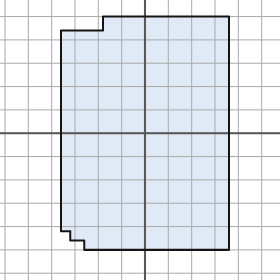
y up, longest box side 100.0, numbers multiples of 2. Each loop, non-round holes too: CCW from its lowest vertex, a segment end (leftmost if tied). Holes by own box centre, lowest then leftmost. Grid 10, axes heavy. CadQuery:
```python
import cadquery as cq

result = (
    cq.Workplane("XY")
    .moveTo(-26.0, -50.0)
    .lineTo(36.0, -50.0)
    .lineTo(36.0, 50.0)
    .lineTo(-18.0, 50.0)
    .lineTo(-18.0, 44.0)
    .lineTo(-36.0, 44.0)
    .lineTo(-36.0, -42.0)
    .lineTo(-32.0, -42.0)
    .lineTo(-32.0, -46.0)
    .lineTo(-26.0, -46.0)
    .close()
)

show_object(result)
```